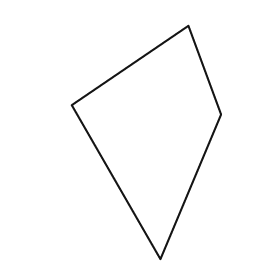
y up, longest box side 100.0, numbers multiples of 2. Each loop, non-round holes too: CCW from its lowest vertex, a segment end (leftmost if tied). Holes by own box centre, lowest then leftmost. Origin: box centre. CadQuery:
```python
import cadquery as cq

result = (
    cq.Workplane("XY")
    .moveTo(6.0, -50.0)
    .lineTo(32.0, 12.0)
    .lineTo(18.0, 50.0)
    .lineTo(-32.0, 16.0)
    .close()
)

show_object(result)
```